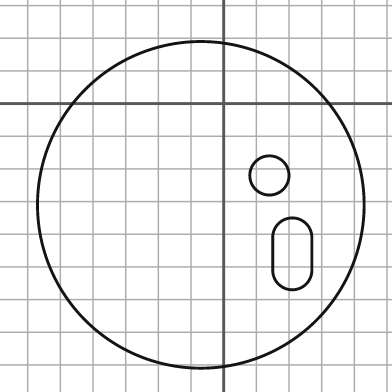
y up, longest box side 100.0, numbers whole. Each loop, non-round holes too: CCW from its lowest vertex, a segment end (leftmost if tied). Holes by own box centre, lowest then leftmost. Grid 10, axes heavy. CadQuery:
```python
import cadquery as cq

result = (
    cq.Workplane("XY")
    .moveTo(-7.0, -31.0)
    .circle(50.0)
    .moveTo(15.0, -51.0)
    .threePointArc((21.0, -57.0), (27.0, -51.0))
    .lineTo(27.0, -41.0)
    .threePointArc((21.0, -35.0), (15.0, -41.0))
    .close()
    .moveTo(14.0, -22.0)
    .circle(6.0)
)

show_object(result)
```